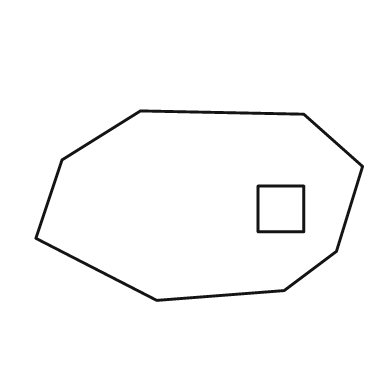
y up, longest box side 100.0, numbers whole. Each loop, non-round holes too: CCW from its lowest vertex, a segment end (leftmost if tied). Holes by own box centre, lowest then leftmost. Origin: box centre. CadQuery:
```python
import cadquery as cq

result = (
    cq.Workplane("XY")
    .moveTo(-13.0, -29.0)
    .lineTo(26.0, -26.0)
    .lineTo(42.0, -14.0)
    .lineTo(50.0, 12.0)
    .lineTo(32.0, 28.0)
    .lineTo(-18.0, 29.0)
    .lineTo(-42.0, 14.0)
    .lineTo(-50.0, -10.0)
    .close()
    .moveTo(18.0, -8.0)
    .lineTo(32.0, -8.0)
    .lineTo(32.0, 6.0)
    .lineTo(18.0, 6.0)
    .close()
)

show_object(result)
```